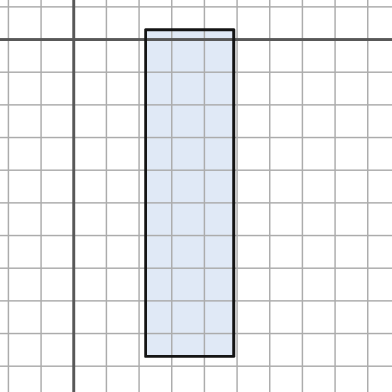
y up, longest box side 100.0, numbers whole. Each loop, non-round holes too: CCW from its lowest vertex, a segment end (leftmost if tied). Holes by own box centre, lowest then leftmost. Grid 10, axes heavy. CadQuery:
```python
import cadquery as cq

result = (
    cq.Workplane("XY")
    .moveTo(22.0, -97.0)
    .lineTo(49.0, -97.0)
    .lineTo(49.0, 3.0)
    .lineTo(22.0, 3.0)
    .close()
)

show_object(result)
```